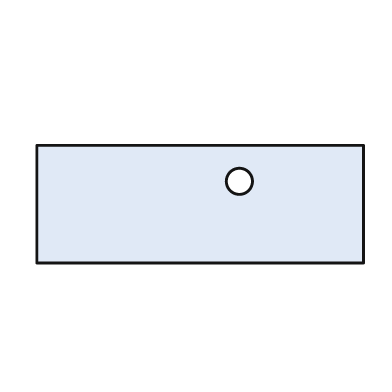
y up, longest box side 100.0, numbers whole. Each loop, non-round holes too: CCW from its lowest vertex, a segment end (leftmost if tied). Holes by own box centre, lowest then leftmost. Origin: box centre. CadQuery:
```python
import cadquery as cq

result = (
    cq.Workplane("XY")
    .moveTo(-50.0, -18.0)
    .lineTo(50.0, -18.0)
    .lineTo(50.0, 18.0)
    .lineTo(-50.0, 18.0)
    .close()
    .moveTo(12.0, 7.0)
    .circle(4.0)
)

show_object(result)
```